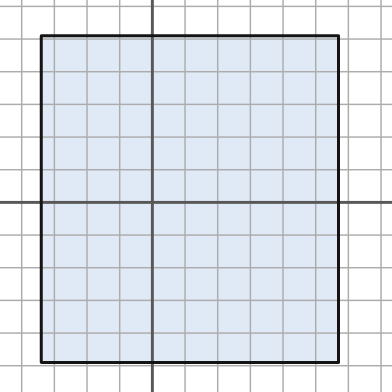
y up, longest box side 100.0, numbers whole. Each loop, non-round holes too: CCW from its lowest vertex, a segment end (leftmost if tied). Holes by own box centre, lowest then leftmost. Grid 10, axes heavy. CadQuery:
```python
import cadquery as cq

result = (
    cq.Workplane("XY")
    .moveTo(-34.0, -49.0)
    .lineTo(57.0, -49.0)
    .lineTo(57.0, 51.0)
    .lineTo(-34.0, 51.0)
    .close()
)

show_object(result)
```